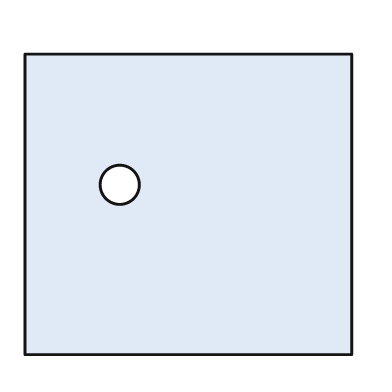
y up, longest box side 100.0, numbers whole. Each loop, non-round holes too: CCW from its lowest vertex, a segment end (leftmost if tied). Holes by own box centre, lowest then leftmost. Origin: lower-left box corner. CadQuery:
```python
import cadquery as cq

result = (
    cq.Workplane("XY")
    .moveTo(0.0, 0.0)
    .lineTo(100.0, 0.0)
    .lineTo(100.0, 92.0)
    .lineTo(0.0, 92.0)
    .close()
    .moveTo(29.0, 52.0)
    .circle(6.0)
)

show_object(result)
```